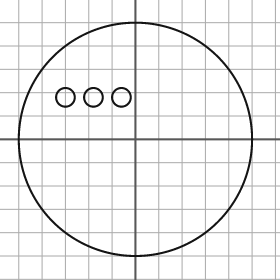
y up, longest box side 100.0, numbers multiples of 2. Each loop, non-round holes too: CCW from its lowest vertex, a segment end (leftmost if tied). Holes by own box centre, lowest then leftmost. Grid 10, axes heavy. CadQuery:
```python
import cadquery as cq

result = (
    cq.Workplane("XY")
    .moveTo(0.0, 0.0)
    .circle(50.0)
    .moveTo(-30.0, 18.0)
    .circle(4.0)
    .moveTo(-18.0, 18.0)
    .circle(4.0)
    .moveTo(-6.0, 18.0)
    .circle(4.0)
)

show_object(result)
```